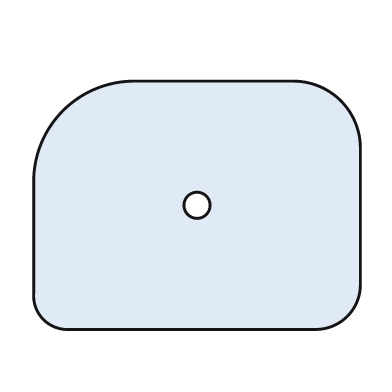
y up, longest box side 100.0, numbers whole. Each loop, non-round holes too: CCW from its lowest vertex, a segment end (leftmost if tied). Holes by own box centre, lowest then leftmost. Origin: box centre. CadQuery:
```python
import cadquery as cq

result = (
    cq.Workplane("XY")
    .moveTo(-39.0, -38.0)
    .lineTo(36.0, -38.0)
    .threePointArc((46.0, -34.0), (50.0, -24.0))
    .lineTo(50.0, 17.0)
    .threePointArc((44.0, 32.0), (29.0, 38.0))
    .lineTo(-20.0, 38.0)
    .threePointArc((-41.0, 29.0), (-50.0, 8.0))
    .lineTo(-50.0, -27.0)
    .threePointArc((-47.0, -35.0), (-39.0, -38.0))
    .close()
    .moveTo(0.0, 0.0)
    .circle(4.0)
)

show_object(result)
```